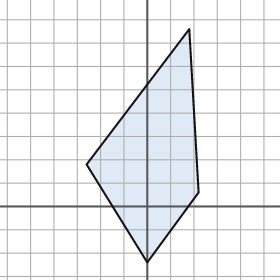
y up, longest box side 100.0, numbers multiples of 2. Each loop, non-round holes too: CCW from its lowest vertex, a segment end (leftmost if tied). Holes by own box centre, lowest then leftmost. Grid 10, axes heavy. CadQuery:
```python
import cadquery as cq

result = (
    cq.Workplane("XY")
    .moveTo(0.0, -24.0)
    .lineTo(22.0, 6.0)
    .lineTo(18.0, 76.0)
    .lineTo(-26.0, 18.0)
    .close()
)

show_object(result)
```